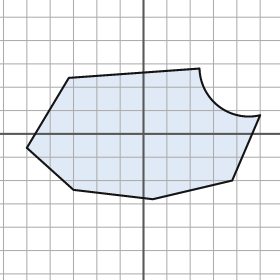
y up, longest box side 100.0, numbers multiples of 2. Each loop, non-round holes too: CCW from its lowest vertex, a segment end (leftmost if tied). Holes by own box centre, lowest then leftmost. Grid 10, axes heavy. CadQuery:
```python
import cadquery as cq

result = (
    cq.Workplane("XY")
    .moveTo(4.0, -28.0)
    .lineTo(38.0, -20.0)
    .lineTo(50.0, 8.0)
    .threePointArc((32.0, 12.0), (24.0, 28.0))
    .lineTo(-32.0, 24.0)
    .lineTo(-50.0, -6.0)
    .lineTo(-30.0, -24.0)
    .close()
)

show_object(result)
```